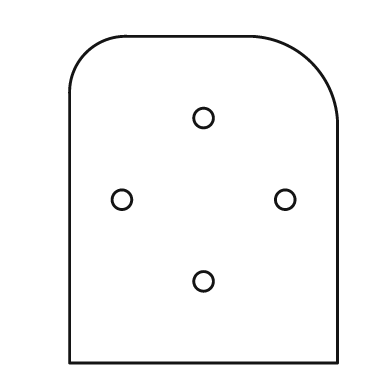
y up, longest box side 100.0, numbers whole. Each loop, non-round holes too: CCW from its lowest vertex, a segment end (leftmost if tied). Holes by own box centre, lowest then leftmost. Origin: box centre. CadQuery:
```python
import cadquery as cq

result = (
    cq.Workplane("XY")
    .moveTo(-41.0, -50.0)
    .lineTo(41.0, -50.0)
    .lineTo(41.0, 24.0)
    .threePointArc((33.0, 42.0), (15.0, 50.0))
    .lineTo(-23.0, 50.0)
    .threePointArc((-36.0, 45.0), (-41.0, 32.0))
    .close()
    .moveTo(0.0, -25.0)
    .circle(3.0)
    .moveTo(-25.0, 0.0)
    .circle(3.0)
    .moveTo(25.0, 0.0)
    .circle(3.0)
    .moveTo(0.0, 25.0)
    .circle(3.0)
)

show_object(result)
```